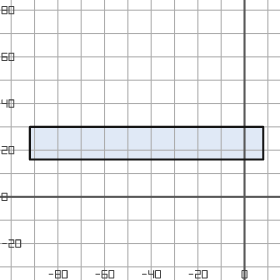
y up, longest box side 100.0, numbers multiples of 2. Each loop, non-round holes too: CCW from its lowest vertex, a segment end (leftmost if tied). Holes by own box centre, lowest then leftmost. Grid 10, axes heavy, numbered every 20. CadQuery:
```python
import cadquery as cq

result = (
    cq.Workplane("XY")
    .moveTo(-92.0, 16.0)
    .lineTo(8.0, 16.0)
    .lineTo(8.0, 30.0)
    .lineTo(-92.0, 30.0)
    .close()
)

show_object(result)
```